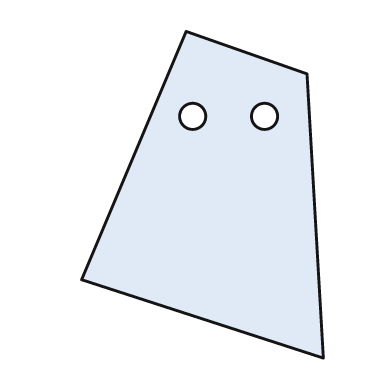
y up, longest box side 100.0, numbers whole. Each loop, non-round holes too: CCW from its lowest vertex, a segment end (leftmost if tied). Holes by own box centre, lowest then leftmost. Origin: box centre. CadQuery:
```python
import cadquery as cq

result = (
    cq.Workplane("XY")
    .moveTo(37.0, -50.0)
    .lineTo(32.0, 37.0)
    .lineTo(-5.0, 50.0)
    .lineTo(-37.0, -26.0)
    .close()
    .moveTo(-3.0, 24.0)
    .circle(4.0)
    .moveTo(19.0, 24.0)
    .circle(4.0)
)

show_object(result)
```